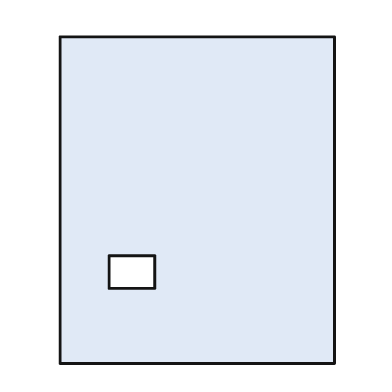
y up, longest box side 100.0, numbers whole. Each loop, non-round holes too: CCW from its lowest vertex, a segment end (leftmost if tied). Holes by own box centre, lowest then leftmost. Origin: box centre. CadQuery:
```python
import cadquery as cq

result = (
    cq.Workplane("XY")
    .moveTo(-42.0, -50.0)
    .lineTo(42.0, -50.0)
    .lineTo(42.0, 50.0)
    .lineTo(-42.0, 50.0)
    .close()
    .moveTo(-27.0, -27.0)
    .lineTo(-13.0, -27.0)
    .lineTo(-13.0, -17.0)
    .lineTo(-27.0, -17.0)
    .close()
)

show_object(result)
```